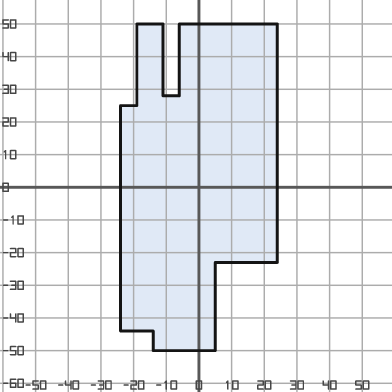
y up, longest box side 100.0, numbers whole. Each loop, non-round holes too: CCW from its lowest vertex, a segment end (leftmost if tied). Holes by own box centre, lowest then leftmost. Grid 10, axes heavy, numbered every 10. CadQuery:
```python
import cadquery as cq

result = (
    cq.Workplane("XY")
    .moveTo(-14.0, -50.0)
    .lineTo(5.0, -50.0)
    .lineTo(5.0, -23.0)
    .lineTo(24.0, -23.0)
    .lineTo(24.0, 50.0)
    .lineTo(-6.0, 50.0)
    .lineTo(-6.0, 28.0)
    .lineTo(-11.0, 28.0)
    .lineTo(-11.0, 50.0)
    .lineTo(-19.0, 50.0)
    .lineTo(-19.0, 25.0)
    .lineTo(-24.0, 25.0)
    .lineTo(-24.0, -44.0)
    .lineTo(-14.0, -44.0)
    .close()
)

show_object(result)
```